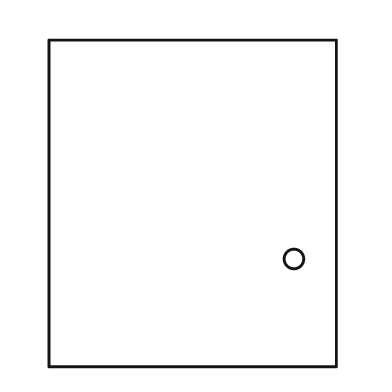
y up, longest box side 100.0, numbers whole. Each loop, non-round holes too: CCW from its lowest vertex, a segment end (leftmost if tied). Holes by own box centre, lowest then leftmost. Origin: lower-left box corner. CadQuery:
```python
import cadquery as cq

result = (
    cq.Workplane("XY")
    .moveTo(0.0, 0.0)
    .lineTo(88.0, 0.0)
    .lineTo(88.0, 100.0)
    .lineTo(0.0, 100.0)
    .close()
    .moveTo(75.0, 33.0)
    .circle(3.0)
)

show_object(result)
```